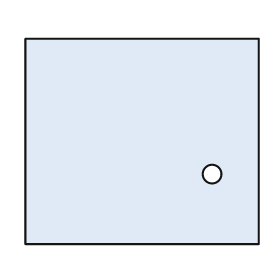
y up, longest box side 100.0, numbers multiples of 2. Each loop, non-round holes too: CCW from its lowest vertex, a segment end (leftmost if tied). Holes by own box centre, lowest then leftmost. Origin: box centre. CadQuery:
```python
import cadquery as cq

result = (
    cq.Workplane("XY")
    .moveTo(-50.0, -44.0)
    .lineTo(50.0, -44.0)
    .lineTo(50.0, 44.0)
    .lineTo(-50.0, 44.0)
    .close()
    .moveTo(30.0, -14.0)
    .circle(4.0)
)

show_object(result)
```